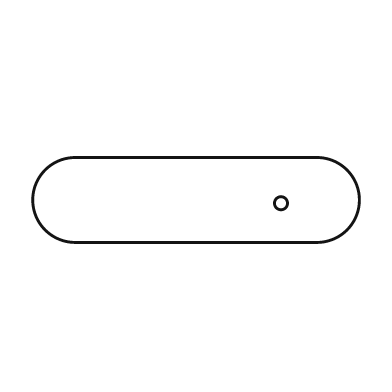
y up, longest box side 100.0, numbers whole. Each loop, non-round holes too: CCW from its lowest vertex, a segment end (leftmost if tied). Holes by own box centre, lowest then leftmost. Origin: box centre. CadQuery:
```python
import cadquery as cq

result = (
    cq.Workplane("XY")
    .moveTo(-37.0, -13.0)
    .lineTo(37.0, -13.0)
    .threePointArc((50.0, 0.0), (37.0, 13.0))
    .lineTo(-37.0, 13.0)
    .threePointArc((-50.0, 0.0), (-37.0, -13.0))
    .close()
    .moveTo(26.0, -1.0)
    .circle(2.0)
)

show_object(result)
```